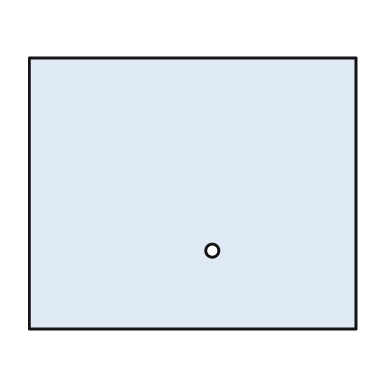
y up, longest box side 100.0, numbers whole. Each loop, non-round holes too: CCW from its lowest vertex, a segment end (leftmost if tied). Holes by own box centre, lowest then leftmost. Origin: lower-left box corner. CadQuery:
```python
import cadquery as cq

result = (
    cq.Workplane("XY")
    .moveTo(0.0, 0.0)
    .lineTo(100.0, 0.0)
    .lineTo(100.0, 83.0)
    .lineTo(0.0, 83.0)
    .close()
    .moveTo(56.0, 24.0)
    .circle(2.0)
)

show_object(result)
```